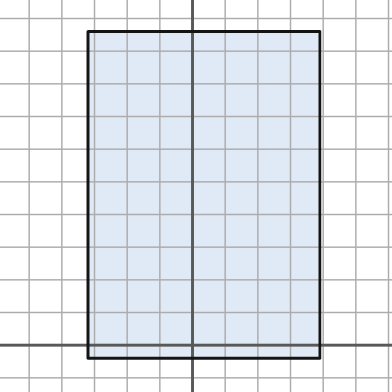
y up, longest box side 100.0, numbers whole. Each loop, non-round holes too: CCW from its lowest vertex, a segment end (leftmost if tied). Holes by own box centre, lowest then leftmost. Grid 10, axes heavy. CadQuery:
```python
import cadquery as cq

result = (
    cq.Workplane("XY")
    .moveTo(-32.0, -4.0)
    .lineTo(39.0, -4.0)
    .lineTo(39.0, 96.0)
    .lineTo(-32.0, 96.0)
    .close()
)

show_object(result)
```